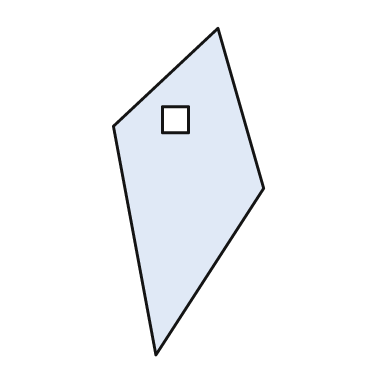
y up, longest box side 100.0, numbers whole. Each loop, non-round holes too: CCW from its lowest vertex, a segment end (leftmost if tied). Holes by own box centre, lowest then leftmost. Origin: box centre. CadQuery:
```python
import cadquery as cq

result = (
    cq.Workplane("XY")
    .moveTo(-10.0, -50.0)
    .lineTo(23.0, 1.0)
    .lineTo(9.0, 50.0)
    .lineTo(-23.0, 20.0)
    .close()
    .moveTo(-8.0, 18.0)
    .lineTo(0.0, 18.0)
    .lineTo(0.0, 26.0)
    .lineTo(-8.0, 26.0)
    .close()
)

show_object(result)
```